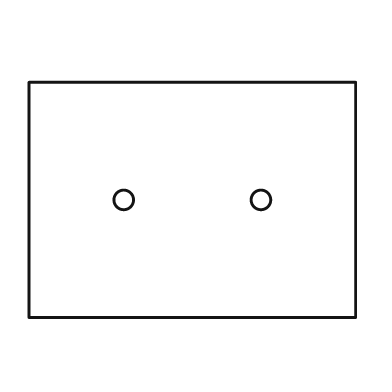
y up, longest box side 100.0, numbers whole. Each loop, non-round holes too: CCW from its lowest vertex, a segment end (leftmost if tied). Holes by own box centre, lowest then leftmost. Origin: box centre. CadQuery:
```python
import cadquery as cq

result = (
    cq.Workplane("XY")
    .moveTo(-50.0, -36.0)
    .lineTo(50.0, -36.0)
    .lineTo(50.0, 36.0)
    .lineTo(-50.0, 36.0)
    .close()
    .moveTo(-21.0, 0.0)
    .circle(3.0)
    .moveTo(21.0, 0.0)
    .circle(3.0)
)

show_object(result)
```